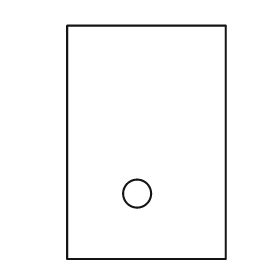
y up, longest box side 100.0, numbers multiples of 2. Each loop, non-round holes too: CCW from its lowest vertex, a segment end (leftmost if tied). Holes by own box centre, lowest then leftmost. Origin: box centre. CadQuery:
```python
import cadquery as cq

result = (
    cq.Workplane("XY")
    .moveTo(-34.0, -50.0)
    .lineTo(34.0, -50.0)
    .lineTo(34.0, 50.0)
    .lineTo(-34.0, 50.0)
    .close()
    .moveTo(-4.0, -22.0)
    .circle(6.0)
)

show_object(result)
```